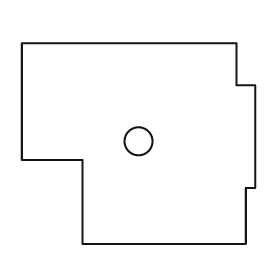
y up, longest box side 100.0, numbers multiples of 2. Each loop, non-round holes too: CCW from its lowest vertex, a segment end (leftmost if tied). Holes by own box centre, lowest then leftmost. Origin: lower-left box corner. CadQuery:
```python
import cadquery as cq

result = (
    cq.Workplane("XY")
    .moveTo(26.0, 0.0)
    .lineTo(96.0, 0.0)
    .lineTo(96.0, 24.0)
    .lineTo(100.0, 24.0)
    .lineTo(100.0, 68.0)
    .lineTo(92.0, 68.0)
    .lineTo(92.0, 86.0)
    .lineTo(0.0, 86.0)
    .lineTo(0.0, 36.0)
    .lineTo(26.0, 36.0)
    .close()
    .moveTo(50.0, 44.0)
    .circle(6.0)
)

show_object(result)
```